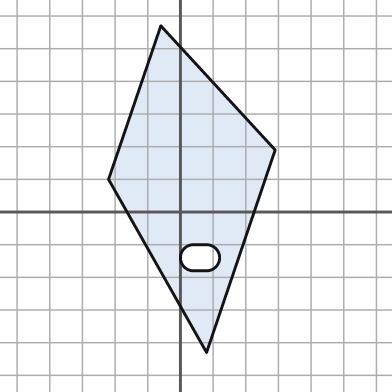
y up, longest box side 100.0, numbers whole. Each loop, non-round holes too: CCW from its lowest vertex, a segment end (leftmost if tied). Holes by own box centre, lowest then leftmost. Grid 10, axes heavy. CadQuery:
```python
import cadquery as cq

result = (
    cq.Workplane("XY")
    .moveTo(8.0, -43.0)
    .lineTo(29.0, 19.0)
    .lineTo(-6.0, 57.0)
    .lineTo(-22.0, 10.0)
    .close()
    .moveTo(4.0, -18.0)
    .lineTo(8.0, -18.0)
    .threePointArc((12.0, -14.0), (8.0, -10.0))
    .lineTo(4.0, -10.0)
    .threePointArc((0.0, -14.0), (4.0, -18.0))
    .close()
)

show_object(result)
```